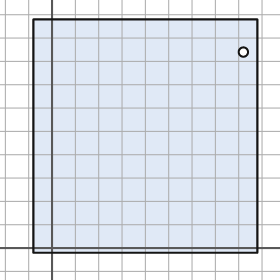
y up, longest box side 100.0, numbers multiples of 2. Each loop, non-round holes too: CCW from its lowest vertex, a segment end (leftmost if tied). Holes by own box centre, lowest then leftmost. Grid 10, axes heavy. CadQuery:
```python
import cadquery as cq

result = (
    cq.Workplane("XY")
    .moveTo(-8.0, -2.0)
    .lineTo(88.0, -2.0)
    .lineTo(88.0, 98.0)
    .lineTo(-8.0, 98.0)
    .close()
    .moveTo(82.0, 84.0)
    .circle(2.0)
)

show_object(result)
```